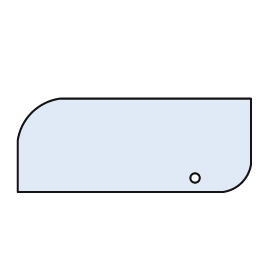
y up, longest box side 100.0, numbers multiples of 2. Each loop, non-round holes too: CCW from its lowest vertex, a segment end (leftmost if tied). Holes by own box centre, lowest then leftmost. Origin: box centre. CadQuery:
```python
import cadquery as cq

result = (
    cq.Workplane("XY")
    .moveTo(-50.0, -20.0)
    .lineTo(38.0, -20.0)
    .threePointArc((46.0, -16.0), (50.0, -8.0))
    .lineTo(50.0, 20.0)
    .lineTo(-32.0, 20.0)
    .threePointArc((-44.0, 14.0), (-50.0, 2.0))
    .close()
    .moveTo(26.0, -14.0)
    .circle(2.0)
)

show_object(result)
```